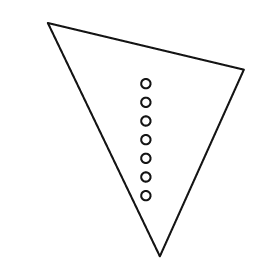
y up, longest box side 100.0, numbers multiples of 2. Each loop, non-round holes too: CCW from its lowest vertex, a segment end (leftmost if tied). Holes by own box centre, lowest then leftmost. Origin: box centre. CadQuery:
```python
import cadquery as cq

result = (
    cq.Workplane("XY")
    .moveTo(6.0, -50.0)
    .lineTo(42.0, 30.0)
    .lineTo(-42.0, 50.0)
    .close()
    .moveTo(0.0, -24.0)
    .circle(2.0)
    .moveTo(0.0, -16.0)
    .circle(2.0)
    .moveTo(0.0, -8.0)
    .circle(2.0)
    .moveTo(0.0, 0.0)
    .circle(2.0)
    .moveTo(0.0, 8.0)
    .circle(2.0)
    .moveTo(0.0, 16.0)
    .circle(2.0)
    .moveTo(0.0, 24.0)
    .circle(2.0)
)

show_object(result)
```